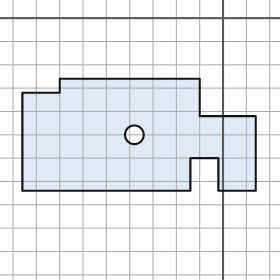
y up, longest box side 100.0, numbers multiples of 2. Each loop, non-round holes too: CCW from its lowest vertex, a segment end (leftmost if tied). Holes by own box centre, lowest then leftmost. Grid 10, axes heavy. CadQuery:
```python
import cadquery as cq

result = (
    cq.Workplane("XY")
    .moveTo(-86.0, -74.0)
    .lineTo(-14.0, -74.0)
    .lineTo(-14.0, -60.0)
    .lineTo(-2.0, -60.0)
    .lineTo(-2.0, -74.0)
    .lineTo(14.0, -74.0)
    .lineTo(14.0, -42.0)
    .lineTo(-10.0, -42.0)
    .lineTo(-10.0, -26.0)
    .lineTo(-70.0, -26.0)
    .lineTo(-70.0, -32.0)
    .lineTo(-86.0, -32.0)
    .close()
    .moveTo(-38.0, -50.0)
    .circle(4.0)
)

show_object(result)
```